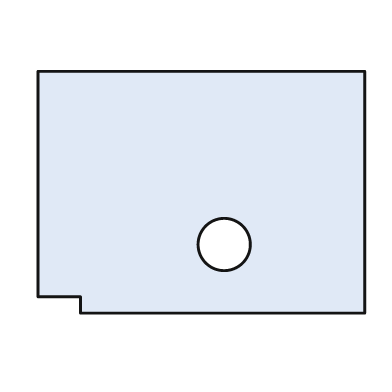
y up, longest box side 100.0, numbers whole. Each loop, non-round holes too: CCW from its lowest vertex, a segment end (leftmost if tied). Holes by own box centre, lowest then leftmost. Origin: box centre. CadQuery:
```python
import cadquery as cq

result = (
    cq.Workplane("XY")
    .moveTo(-37.0, -37.0)
    .lineTo(50.0, -37.0)
    .lineTo(50.0, 37.0)
    .lineTo(-50.0, 37.0)
    .lineTo(-50.0, -32.0)
    .lineTo(-37.0, -32.0)
    .close()
    .moveTo(7.0, -16.0)
    .circle(8.0)
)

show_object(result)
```